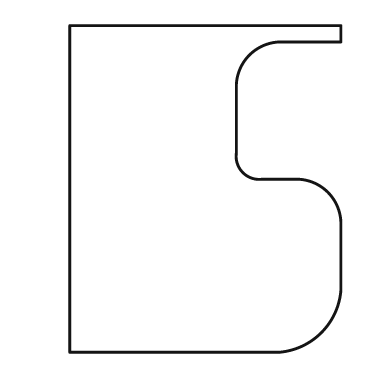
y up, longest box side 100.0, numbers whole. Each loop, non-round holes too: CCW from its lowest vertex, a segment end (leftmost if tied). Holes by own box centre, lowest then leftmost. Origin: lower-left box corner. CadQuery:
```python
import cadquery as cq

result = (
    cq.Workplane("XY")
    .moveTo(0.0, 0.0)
    .lineTo(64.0, 0.0)
    .threePointArc((77.0, 6.0), (83.0, 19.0))
    .lineTo(83.0, 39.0)
    .threePointArc((79.0, 49.0), (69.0, 53.0))
    .lineTo(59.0, 53.0)
    .threePointArc((53.0, 55.0), (51.0, 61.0))
    .lineTo(51.0, 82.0)
    .threePointArc((55.0, 91.0), (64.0, 95.0))
    .lineTo(83.0, 95.0)
    .lineTo(83.0, 100.0)
    .lineTo(0.0, 100.0)
    .close()
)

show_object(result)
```